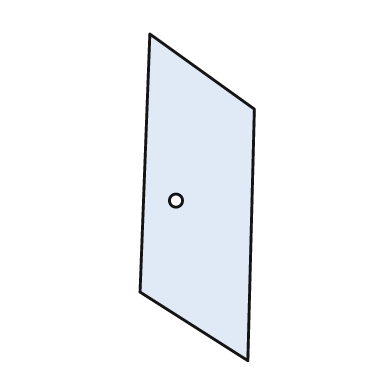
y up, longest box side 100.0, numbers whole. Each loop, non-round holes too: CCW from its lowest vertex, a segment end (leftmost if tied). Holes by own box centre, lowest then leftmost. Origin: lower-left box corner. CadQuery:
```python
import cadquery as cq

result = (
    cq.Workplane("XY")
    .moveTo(33.0, 0.0)
    .lineTo(35.0, 77.0)
    .lineTo(3.0, 100.0)
    .lineTo(0.0, 21.0)
    .close()
    .moveTo(11.0, 49.0)
    .circle(2.0)
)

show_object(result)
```